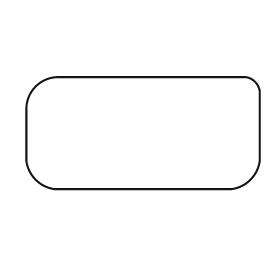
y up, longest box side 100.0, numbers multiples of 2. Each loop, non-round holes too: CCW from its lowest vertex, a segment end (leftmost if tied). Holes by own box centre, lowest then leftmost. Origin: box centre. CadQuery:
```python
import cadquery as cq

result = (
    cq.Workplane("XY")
    .moveTo(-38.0, -24.0)
    .lineTo(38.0, -24.0)
    .threePointArc((46.0, -20.0), (50.0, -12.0))
    .lineTo(50.0, 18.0)
    .threePointArc((48.0, 22.0), (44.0, 24.0))
    .lineTo(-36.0, 24.0)
    .threePointArc((-46.0, 20.0), (-50.0, 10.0))
    .lineTo(-50.0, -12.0)
    .threePointArc((-46.0, -20.0), (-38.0, -24.0))
    .close()
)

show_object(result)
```